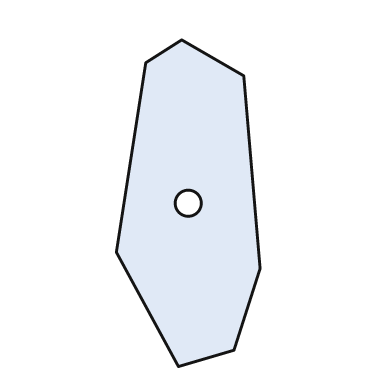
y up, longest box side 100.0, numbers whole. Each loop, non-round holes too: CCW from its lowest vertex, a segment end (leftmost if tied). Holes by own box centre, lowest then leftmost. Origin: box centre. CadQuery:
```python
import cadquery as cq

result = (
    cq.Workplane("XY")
    .moveTo(-3.0, -50.0)
    .lineTo(14.0, -45.0)
    .lineTo(22.0, -20.0)
    .lineTo(17.0, 39.0)
    .lineTo(-2.0, 50.0)
    .lineTo(-13.0, 43.0)
    .lineTo(-22.0, -15.0)
    .close()
    .moveTo(0.0, 0.0)
    .circle(4.0)
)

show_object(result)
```